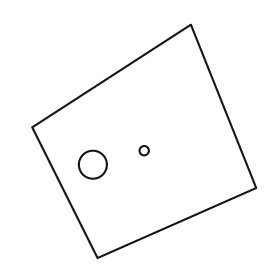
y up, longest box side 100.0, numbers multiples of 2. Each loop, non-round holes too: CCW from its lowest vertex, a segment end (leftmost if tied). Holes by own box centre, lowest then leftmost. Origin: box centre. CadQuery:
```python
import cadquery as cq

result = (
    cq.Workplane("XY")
    .moveTo(-20.0, -50.0)
    .lineTo(48.0, -20.0)
    .lineTo(20.0, 50.0)
    .lineTo(-48.0, 6.0)
    .close()
    .moveTo(-22.0, -10.0)
    .circle(6.0)
    .moveTo(0.0, -4.0)
    .circle(2.0)
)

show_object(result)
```